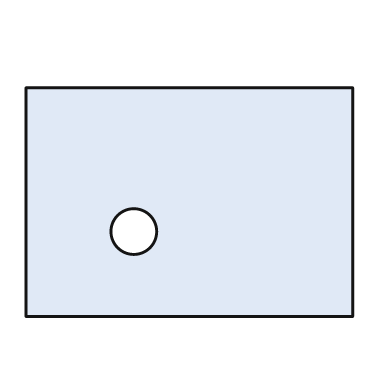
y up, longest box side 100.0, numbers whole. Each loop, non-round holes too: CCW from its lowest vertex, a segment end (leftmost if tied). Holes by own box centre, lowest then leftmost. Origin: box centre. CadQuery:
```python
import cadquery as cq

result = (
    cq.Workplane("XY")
    .moveTo(-50.0, -35.0)
    .lineTo(50.0, -35.0)
    .lineTo(50.0, 35.0)
    .lineTo(-50.0, 35.0)
    .close()
    .moveTo(-17.0, -9.0)
    .circle(7.0)
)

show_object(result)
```